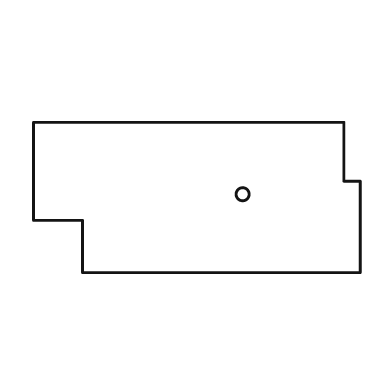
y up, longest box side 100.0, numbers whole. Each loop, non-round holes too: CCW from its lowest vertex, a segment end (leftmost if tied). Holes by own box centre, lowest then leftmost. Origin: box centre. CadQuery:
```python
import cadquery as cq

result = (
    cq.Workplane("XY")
    .moveTo(-35.0, -23.0)
    .lineTo(50.0, -23.0)
    .lineTo(50.0, 5.0)
    .lineTo(45.0, 5.0)
    .lineTo(45.0, 23.0)
    .lineTo(-50.0, 23.0)
    .lineTo(-50.0, -7.0)
    .lineTo(-35.0, -7.0)
    .close()
    .moveTo(14.0, 1.0)
    .circle(2.0)
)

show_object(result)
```